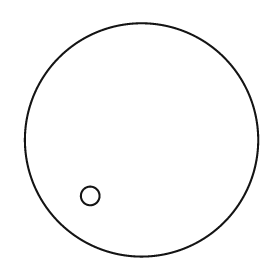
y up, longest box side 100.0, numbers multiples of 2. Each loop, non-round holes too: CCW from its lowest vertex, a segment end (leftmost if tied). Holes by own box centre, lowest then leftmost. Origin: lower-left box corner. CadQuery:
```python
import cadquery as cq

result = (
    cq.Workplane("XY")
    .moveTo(50.0, 50.0)
    .circle(50.0)
    .moveTo(28.0, 26.0)
    .circle(4.0)
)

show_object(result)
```